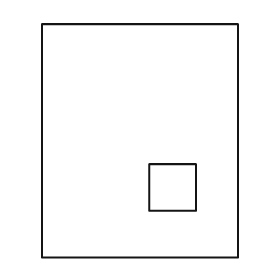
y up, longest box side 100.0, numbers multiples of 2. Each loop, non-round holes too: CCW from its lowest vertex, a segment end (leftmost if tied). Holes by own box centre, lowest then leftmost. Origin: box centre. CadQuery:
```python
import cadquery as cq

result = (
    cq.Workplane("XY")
    .moveTo(-42.0, -50.0)
    .lineTo(42.0, -50.0)
    .lineTo(42.0, 50.0)
    .lineTo(-42.0, 50.0)
    .close()
    .moveTo(4.0, -30.0)
    .lineTo(24.0, -30.0)
    .lineTo(24.0, -10.0)
    .lineTo(4.0, -10.0)
    .close()
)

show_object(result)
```